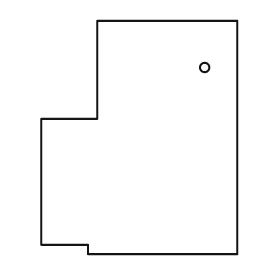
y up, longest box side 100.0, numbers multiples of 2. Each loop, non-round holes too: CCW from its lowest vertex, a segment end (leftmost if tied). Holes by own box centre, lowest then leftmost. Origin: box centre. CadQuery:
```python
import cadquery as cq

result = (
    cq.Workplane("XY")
    .moveTo(-22.0, -50.0)
    .lineTo(42.0, -50.0)
    .lineTo(42.0, 50.0)
    .lineTo(-18.0, 50.0)
    .lineTo(-18.0, 8.0)
    .lineTo(-42.0, 8.0)
    .lineTo(-42.0, -46.0)
    .lineTo(-22.0, -46.0)
    .close()
    .moveTo(28.0, 30.0)
    .circle(2.0)
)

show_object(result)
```